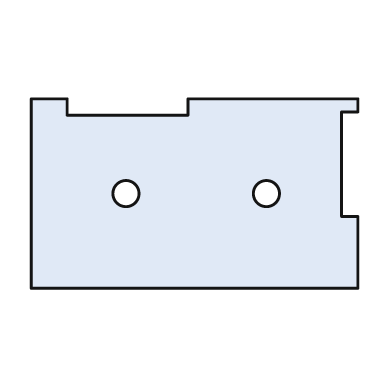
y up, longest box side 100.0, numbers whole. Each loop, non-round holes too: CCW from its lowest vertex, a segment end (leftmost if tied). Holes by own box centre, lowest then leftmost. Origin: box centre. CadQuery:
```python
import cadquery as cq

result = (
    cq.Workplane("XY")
    .moveTo(-50.0, -29.0)
    .lineTo(50.0, -29.0)
    .lineTo(50.0, -7.0)
    .lineTo(45.0, -7.0)
    .lineTo(45.0, 25.0)
    .lineTo(50.0, 25.0)
    .lineTo(50.0, 29.0)
    .lineTo(-2.0, 29.0)
    .lineTo(-2.0, 24.0)
    .lineTo(-39.0, 24.0)
    .lineTo(-39.0, 29.0)
    .lineTo(-50.0, 29.0)
    .close()
    .moveTo(-21.0, 0.0)
    .circle(4.0)
    .moveTo(22.0, 0.0)
    .circle(4.0)
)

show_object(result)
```